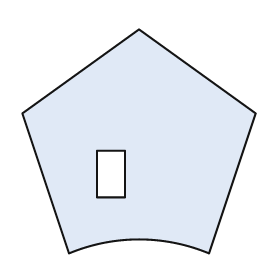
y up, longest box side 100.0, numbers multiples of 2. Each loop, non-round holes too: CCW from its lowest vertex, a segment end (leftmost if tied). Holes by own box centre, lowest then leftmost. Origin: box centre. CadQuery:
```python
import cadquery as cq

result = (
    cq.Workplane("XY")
    .moveTo(-30.0, -48.0)
    .threePointArc((0.0, -42.0), (30.0, -48.0))
    .lineTo(50.0, 12.0)
    .lineTo(0.0, 48.0)
    .lineTo(-50.0, 12.0)
    .close()
    .moveTo(-18.0, -24.0)
    .lineTo(-6.0, -24.0)
    .lineTo(-6.0, -4.0)
    .lineTo(-18.0, -4.0)
    .close()
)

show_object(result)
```